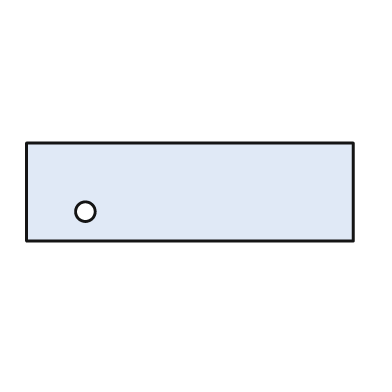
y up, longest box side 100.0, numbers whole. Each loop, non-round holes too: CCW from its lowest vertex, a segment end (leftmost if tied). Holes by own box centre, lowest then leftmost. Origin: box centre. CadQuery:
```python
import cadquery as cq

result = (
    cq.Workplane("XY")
    .moveTo(-50.0, -15.0)
    .lineTo(50.0, -15.0)
    .lineTo(50.0, 15.0)
    .lineTo(-50.0, 15.0)
    .close()
    .moveTo(-32.0, -6.0)
    .circle(3.0)
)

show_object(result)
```